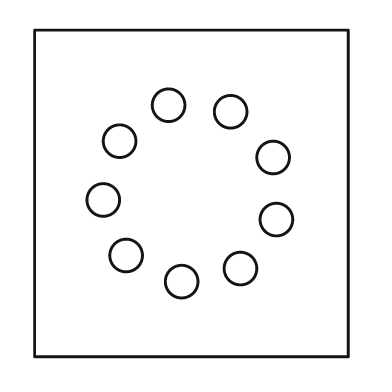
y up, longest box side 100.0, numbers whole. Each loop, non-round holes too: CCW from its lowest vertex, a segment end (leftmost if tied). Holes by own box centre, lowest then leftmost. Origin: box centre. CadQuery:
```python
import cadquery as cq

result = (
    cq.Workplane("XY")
    .moveTo(-48.0, -50.0)
    .lineTo(48.0, -50.0)
    .lineTo(48.0, 50.0)
    .lineTo(-48.0, 50.0)
    .close()
    .moveTo(-3.0, -27.0)
    .circle(5.0)
    .moveTo(15.0, -23.0)
    .circle(5.0)
    .moveTo(-20.0, -19.0)
    .circle(5.0)
    .moveTo(26.0, -8.0)
    .circle(5.0)
    .moveTo(-27.0, -2.0)
    .circle(5.0)
    .moveTo(25.0, 11.0)
    .circle(5.0)
    .moveTo(-22.0, 16.0)
    .circle(5.0)
    .moveTo(12.0, 25.0)
    .circle(5.0)
    .moveTo(-7.0, 27.0)
    .circle(5.0)
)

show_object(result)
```